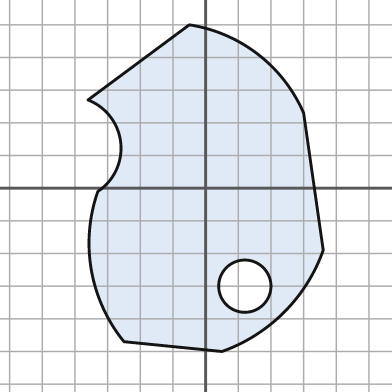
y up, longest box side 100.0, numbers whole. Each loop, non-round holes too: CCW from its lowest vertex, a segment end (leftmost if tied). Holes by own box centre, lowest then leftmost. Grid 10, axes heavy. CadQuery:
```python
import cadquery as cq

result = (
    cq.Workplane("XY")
    .moveTo(5.0, -50.0)
    .threePointArc((24.0, -38.0), (36.0, -19.0))
    .lineTo(30.0, 23.0)
    .threePointArc((16.0, 41.0), (-5.0, 50.0))
    .lineTo(-36.0, 27.0)
    .threePointArc((-26.0, 14.0), (-33.0, -1.0))
    .threePointArc((-35.0, -25.0), (-25.0, -47.0))
    .close()
    .moveTo(12.0, -30.0)
    .circle(8.0)
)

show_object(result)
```